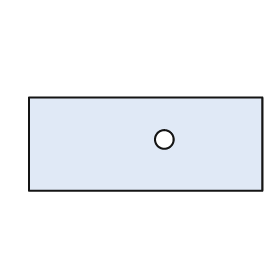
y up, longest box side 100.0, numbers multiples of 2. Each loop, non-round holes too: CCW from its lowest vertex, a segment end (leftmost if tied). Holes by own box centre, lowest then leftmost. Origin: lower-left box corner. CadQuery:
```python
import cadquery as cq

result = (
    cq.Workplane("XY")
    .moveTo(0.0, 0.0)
    .lineTo(100.0, 0.0)
    .lineTo(100.0, 40.0)
    .lineTo(0.0, 40.0)
    .close()
    .moveTo(58.0, 22.0)
    .circle(4.0)
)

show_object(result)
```